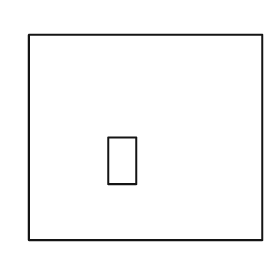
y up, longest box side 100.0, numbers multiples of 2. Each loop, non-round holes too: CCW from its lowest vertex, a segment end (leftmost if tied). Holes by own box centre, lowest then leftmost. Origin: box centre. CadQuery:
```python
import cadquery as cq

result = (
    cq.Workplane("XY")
    .moveTo(-50.0, -44.0)
    .lineTo(50.0, -44.0)
    .lineTo(50.0, 44.0)
    .lineTo(-50.0, 44.0)
    .close()
    .moveTo(-16.0, -20.0)
    .lineTo(-4.0, -20.0)
    .lineTo(-4.0, 0.0)
    .lineTo(-16.0, 0.0)
    .close()
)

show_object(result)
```